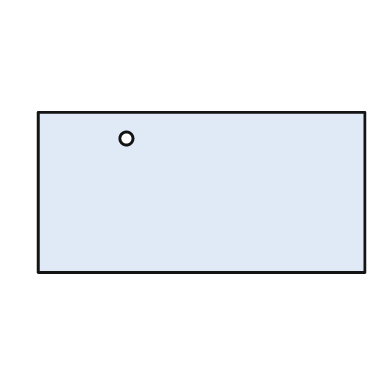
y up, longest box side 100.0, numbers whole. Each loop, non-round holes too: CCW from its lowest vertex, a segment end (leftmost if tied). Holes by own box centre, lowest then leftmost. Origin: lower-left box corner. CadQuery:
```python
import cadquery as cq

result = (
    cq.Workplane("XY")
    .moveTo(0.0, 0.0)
    .lineTo(100.0, 0.0)
    .lineTo(100.0, 49.0)
    .lineTo(0.0, 49.0)
    .close()
    .moveTo(27.0, 41.0)
    .circle(2.0)
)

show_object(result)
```